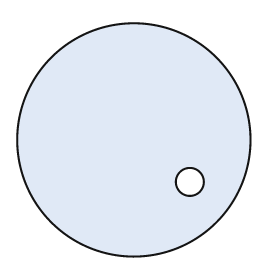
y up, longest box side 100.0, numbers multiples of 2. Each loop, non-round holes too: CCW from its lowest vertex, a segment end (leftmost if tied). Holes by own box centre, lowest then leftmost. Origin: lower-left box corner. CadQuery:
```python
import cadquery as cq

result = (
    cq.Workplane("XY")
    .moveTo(50.0, 50.0)
    .circle(50.0)
    .moveTo(74.0, 32.0)
    .circle(6.0)
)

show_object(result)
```